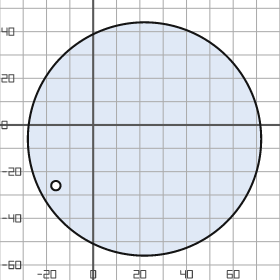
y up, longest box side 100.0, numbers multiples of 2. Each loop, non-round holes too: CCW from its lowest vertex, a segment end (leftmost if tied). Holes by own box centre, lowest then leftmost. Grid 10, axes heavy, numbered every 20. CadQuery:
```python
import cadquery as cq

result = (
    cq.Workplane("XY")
    .moveTo(22.0, -6.0)
    .circle(50.0)
    .moveTo(-16.0, -26.0)
    .circle(2.0)
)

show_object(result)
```